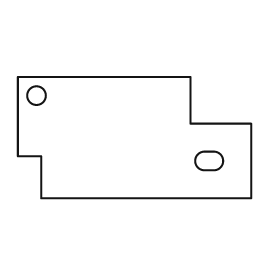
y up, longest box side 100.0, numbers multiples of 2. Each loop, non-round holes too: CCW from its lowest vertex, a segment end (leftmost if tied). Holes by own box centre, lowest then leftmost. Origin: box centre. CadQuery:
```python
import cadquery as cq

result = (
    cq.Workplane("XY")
    .moveTo(-40.0, -26.0)
    .lineTo(50.0, -26.0)
    .lineTo(50.0, 6.0)
    .lineTo(24.0, 6.0)
    .lineTo(24.0, 26.0)
    .lineTo(-50.0, 26.0)
    .lineTo(-50.0, -8.0)
    .lineTo(-40.0, -8.0)
    .close()
    .moveTo(30.0, -14.0)
    .lineTo(34.0, -14.0)
    .threePointArc((38.0, -10.0), (34.0, -6.0))
    .lineTo(30.0, -6.0)
    .threePointArc((26.0, -10.0), (30.0, -14.0))
    .close()
    .moveTo(-42.0, 18.0)
    .circle(4.0)
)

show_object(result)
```